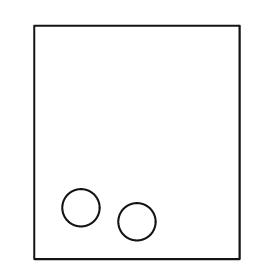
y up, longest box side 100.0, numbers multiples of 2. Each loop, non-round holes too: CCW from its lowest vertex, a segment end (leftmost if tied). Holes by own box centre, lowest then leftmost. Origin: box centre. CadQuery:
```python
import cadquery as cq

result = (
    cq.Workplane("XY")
    .moveTo(-44.0, -50.0)
    .lineTo(44.0, -50.0)
    .lineTo(44.0, 50.0)
    .lineTo(-44.0, 50.0)
    .close()
    .moveTo(0.0, -34.0)
    .circle(8.0)
    .moveTo(-24.0, -28.0)
    .circle(8.0)
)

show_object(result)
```